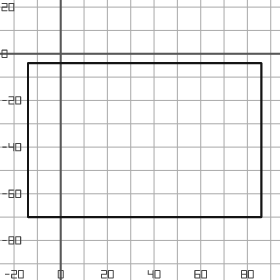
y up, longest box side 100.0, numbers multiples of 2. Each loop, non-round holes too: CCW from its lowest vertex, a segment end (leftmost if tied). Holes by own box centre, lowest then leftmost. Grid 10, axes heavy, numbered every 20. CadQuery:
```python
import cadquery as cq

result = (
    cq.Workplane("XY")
    .moveTo(-14.0, -70.0)
    .lineTo(86.0, -70.0)
    .lineTo(86.0, -4.0)
    .lineTo(-14.0, -4.0)
    .close()
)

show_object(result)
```